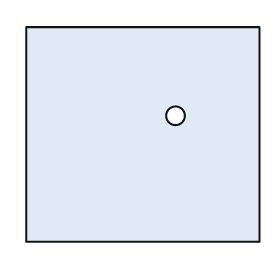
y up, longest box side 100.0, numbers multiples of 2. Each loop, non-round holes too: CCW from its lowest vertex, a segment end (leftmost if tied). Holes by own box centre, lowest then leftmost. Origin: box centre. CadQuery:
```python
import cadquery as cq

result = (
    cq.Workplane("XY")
    .moveTo(-50.0, -46.0)
    .lineTo(50.0, -46.0)
    .lineTo(50.0, 46.0)
    .lineTo(-50.0, 46.0)
    .close()
    .moveTo(14.0, 8.0)
    .circle(4.0)
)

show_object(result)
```